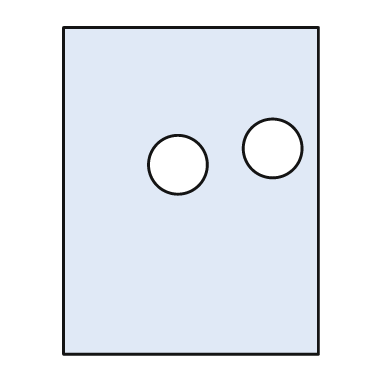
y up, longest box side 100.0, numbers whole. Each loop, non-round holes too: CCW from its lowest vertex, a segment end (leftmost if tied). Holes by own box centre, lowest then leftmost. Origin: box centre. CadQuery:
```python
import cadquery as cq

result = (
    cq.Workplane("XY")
    .moveTo(-39.0, -50.0)
    .lineTo(39.0, -50.0)
    .lineTo(39.0, 50.0)
    .lineTo(-39.0, 50.0)
    .close()
    .moveTo(-4.0, 8.0)
    .circle(9.0)
    .moveTo(25.0, 13.0)
    .circle(9.0)
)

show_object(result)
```